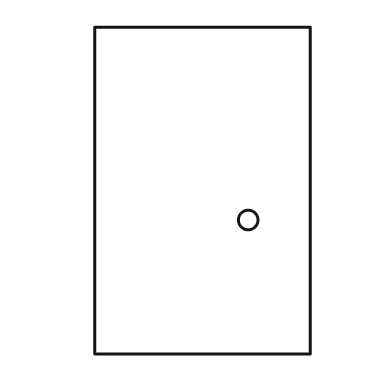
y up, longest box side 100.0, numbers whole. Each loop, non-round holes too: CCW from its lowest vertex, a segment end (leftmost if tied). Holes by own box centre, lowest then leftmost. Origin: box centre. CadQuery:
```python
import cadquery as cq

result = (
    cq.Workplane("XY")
    .moveTo(-33.0, -50.0)
    .lineTo(33.0, -50.0)
    .lineTo(33.0, 50.0)
    .lineTo(-33.0, 50.0)
    .close()
    .moveTo(14.0, -9.0)
    .circle(3.0)
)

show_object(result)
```